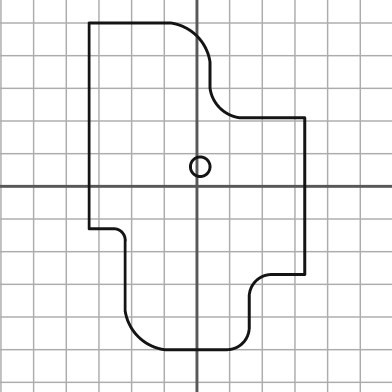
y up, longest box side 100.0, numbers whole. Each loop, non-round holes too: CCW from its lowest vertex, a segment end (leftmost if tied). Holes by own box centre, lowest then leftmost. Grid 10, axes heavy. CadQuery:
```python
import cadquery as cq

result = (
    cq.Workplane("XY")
    .moveTo(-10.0, -50.0)
    .lineTo(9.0, -50.0)
    .threePointArc((14.0, -48.0), (16.0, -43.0))
    .lineTo(16.0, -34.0)
    .threePointArc((18.0, -29.0), (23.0, -27.0))
    .lineTo(33.0, -27.0)
    .lineTo(33.0, 21.0)
    .lineTo(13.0, 21.0)
    .threePointArc((7.0, 24.0), (4.0, 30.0))
    .lineTo(4.0, 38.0)
    .threePointArc((0.0, 46.0), (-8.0, 50.0))
    .lineTo(-33.0, 50.0)
    .lineTo(-33.0, -13.0)
    .lineTo(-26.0, -13.0)
    .threePointArc((-23.0, -14.0), (-22.0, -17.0))
    .lineTo(-22.0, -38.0)
    .threePointArc((-18.0, -46.0), (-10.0, -50.0))
    .close()
    .moveTo(1.0, 6.0)
    .circle(3.0)
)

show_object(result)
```